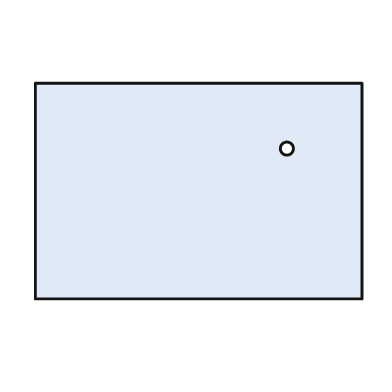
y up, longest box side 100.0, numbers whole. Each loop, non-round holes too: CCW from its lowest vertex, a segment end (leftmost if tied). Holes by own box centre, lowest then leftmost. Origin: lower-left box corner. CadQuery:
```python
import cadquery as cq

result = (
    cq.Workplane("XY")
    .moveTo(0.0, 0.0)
    .lineTo(100.0, 0.0)
    .lineTo(100.0, 66.0)
    .lineTo(0.0, 66.0)
    .close()
    .moveTo(77.0, 46.0)
    .circle(2.0)
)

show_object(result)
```